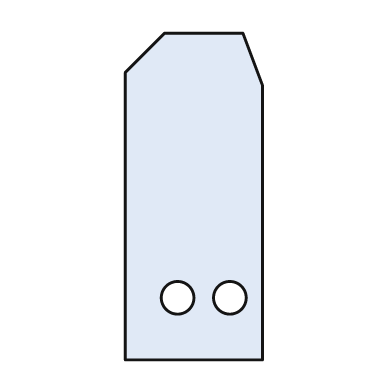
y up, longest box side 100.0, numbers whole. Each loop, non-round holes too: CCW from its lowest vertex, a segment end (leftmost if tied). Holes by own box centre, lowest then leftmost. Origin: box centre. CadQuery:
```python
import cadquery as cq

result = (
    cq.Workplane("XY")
    .moveTo(-21.0, -50.0)
    .lineTo(21.0, -50.0)
    .lineTo(21.0, 34.0)
    .lineTo(15.0, 50.0)
    .lineTo(-9.0, 50.0)
    .lineTo(-21.0, 38.0)
    .close()
    .moveTo(-5.0, -31.0)
    .circle(5.0)
    .moveTo(11.0, -31.0)
    .circle(5.0)
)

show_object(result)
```